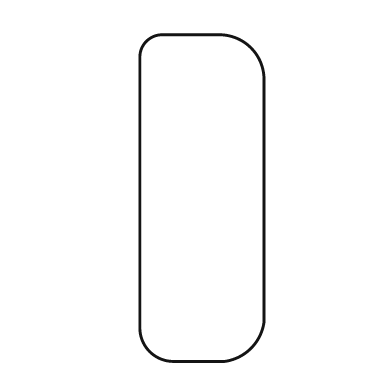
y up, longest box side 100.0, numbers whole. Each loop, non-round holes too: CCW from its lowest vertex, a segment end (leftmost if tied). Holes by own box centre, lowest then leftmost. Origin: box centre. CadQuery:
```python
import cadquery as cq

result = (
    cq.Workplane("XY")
    .moveTo(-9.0, -50.0)
    .lineTo(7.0, -50.0)
    .threePointArc((15.0, -46.0), (19.0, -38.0))
    .lineTo(19.0, 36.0)
    .threePointArc((15.0, 46.0), (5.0, 50.0))
    .lineTo(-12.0, 50.0)
    .threePointArc((-17.0, 48.0), (-19.0, 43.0))
    .lineTo(-19.0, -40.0)
    .threePointArc((-16.0, -47.0), (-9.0, -50.0))
    .close()
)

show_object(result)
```